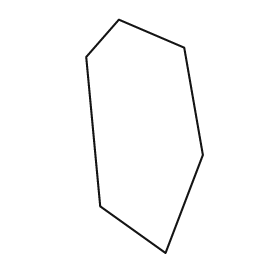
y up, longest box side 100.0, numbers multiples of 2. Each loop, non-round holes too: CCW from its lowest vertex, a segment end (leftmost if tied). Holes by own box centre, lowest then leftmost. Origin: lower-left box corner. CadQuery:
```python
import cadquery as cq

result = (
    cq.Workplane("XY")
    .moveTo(34.0, 0.0)
    .lineTo(50.0, 42.0)
    .lineTo(42.0, 88.0)
    .lineTo(14.0, 100.0)
    .lineTo(0.0, 84.0)
    .lineTo(6.0, 20.0)
    .close()
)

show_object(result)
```